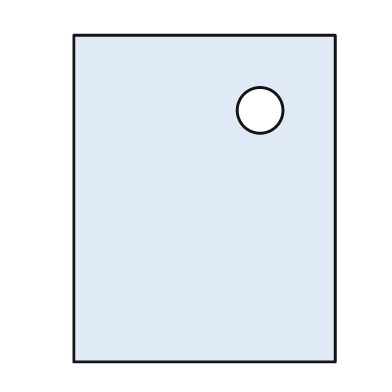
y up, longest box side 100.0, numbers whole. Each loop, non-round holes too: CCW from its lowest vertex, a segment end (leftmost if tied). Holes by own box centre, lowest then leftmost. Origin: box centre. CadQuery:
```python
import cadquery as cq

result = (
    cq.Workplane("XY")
    .moveTo(-40.0, -50.0)
    .lineTo(40.0, -50.0)
    .lineTo(40.0, 50.0)
    .lineTo(-40.0, 50.0)
    .close()
    .moveTo(17.0, 27.0)
    .circle(7.0)
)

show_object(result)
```